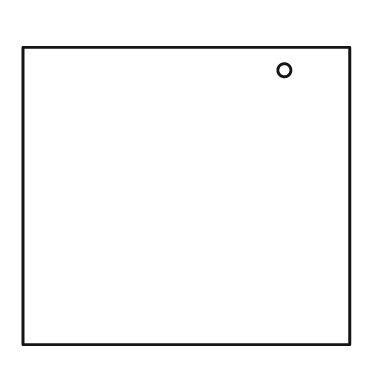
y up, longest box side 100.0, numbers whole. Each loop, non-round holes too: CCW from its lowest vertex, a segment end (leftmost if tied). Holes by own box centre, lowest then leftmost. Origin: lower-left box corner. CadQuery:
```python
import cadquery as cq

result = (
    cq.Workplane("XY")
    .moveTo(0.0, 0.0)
    .lineTo(100.0, 0.0)
    .lineTo(100.0, 91.0)
    .lineTo(0.0, 91.0)
    .close()
    .moveTo(80.0, 84.0)
    .circle(2.0)
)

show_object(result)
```